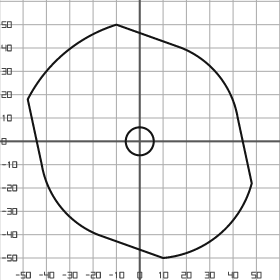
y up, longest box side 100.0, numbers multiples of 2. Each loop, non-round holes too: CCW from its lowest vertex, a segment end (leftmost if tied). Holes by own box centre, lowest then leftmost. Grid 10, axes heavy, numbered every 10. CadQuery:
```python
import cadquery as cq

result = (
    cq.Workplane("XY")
    .moveTo(10.0, -50.0)
    .threePointArc((34.0, -40.0), (48.0, -18.0))
    .lineTo(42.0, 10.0)
    .threePointArc((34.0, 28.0), (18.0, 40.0))
    .lineTo(-10.0, 50.0)
    .threePointArc((-32.0, 38.0), (-48.0, 18.0))
    .lineTo(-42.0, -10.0)
    .threePointArc((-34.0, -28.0), (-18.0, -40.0))
    .close()
    .moveTo(0.0, 0.0)
    .circle(6.0)
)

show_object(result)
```